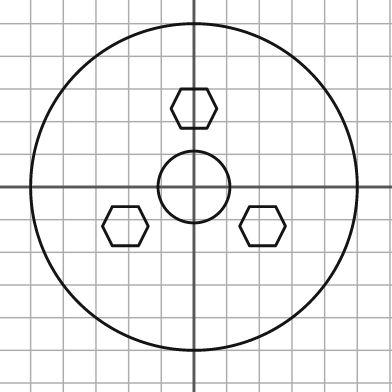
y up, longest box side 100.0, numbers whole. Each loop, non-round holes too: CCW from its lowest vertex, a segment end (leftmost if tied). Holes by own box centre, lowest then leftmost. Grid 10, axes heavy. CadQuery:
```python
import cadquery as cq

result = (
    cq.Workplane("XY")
    .moveTo(0.0, 0.0)
    .circle(50.0)
    .moveTo(-25.0, -18.0)
    .lineTo(-17.0, -18.0)
    .lineTo(-14.0, -12.0)
    .lineTo(-17.0, -6.0)
    .lineTo(-25.0, -6.0)
    .lineTo(-28.0, -12.0)
    .close()
    .moveTo(17.0, -18.0)
    .lineTo(25.0, -18.0)
    .lineTo(28.0, -12.0)
    .lineTo(25.0, -6.0)
    .lineTo(17.0, -6.0)
    .lineTo(14.0, -12.0)
    .close()
    .moveTo(0.0, 0.0)
    .circle(11.0)
    .moveTo(-4.0, 18.0)
    .lineTo(4.0, 18.0)
    .lineTo(7.0, 24.0)
    .lineTo(4.0, 30.0)
    .lineTo(-4.0, 30.0)
    .lineTo(-7.0, 24.0)
    .close()
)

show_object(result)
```